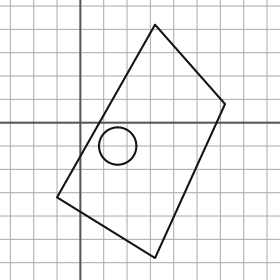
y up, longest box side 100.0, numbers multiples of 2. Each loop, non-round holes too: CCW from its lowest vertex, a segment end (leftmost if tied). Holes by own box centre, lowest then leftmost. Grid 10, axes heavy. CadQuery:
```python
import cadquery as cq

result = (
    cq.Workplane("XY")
    .moveTo(32.0, -58.0)
    .lineTo(62.0, 8.0)
    .lineTo(32.0, 42.0)
    .lineTo(-10.0, -32.0)
    .close()
    .moveTo(16.0, -10.0)
    .circle(8.0)
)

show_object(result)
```